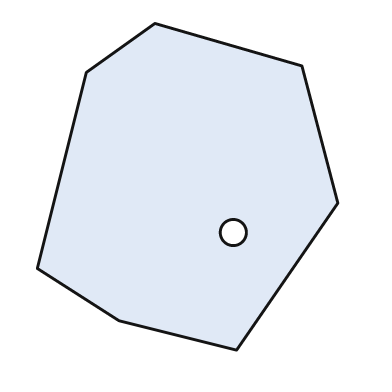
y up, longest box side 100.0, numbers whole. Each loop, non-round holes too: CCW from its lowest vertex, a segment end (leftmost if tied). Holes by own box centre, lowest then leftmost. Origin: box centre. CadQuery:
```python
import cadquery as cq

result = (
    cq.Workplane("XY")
    .moveTo(15.0, -50.0)
    .lineTo(46.0, -5.0)
    .lineTo(35.0, 37.0)
    .lineTo(-10.0, 50.0)
    .lineTo(-31.0, 35.0)
    .lineTo(-46.0, -25.0)
    .lineTo(-21.0, -41.0)
    .close()
    .moveTo(14.0, -14.0)
    .circle(4.0)
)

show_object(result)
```